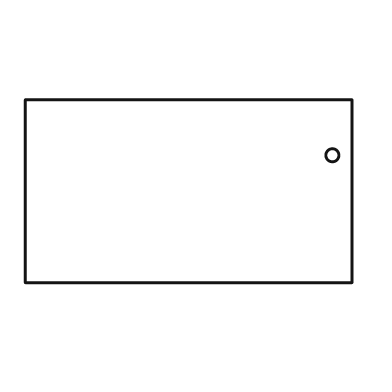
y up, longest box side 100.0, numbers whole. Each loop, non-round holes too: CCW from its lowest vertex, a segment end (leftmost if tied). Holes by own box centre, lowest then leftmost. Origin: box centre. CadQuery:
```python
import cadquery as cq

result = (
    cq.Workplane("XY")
    .moveTo(-50.0, -28.0)
    .lineTo(50.0, -28.0)
    .lineTo(50.0, 28.0)
    .lineTo(-50.0, 28.0)
    .close()
    .moveTo(44.0, 11.0)
    .circle(2.0)
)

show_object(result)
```